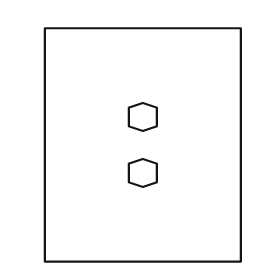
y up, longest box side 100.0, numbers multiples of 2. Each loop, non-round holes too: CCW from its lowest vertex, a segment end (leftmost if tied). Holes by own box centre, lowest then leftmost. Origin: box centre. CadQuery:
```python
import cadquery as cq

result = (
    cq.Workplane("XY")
    .moveTo(-42.0, -50.0)
    .lineTo(42.0, -50.0)
    .lineTo(42.0, 50.0)
    .lineTo(-42.0, 50.0)
    .close()
    .moveTo(0.0, -18.0)
    .lineTo(6.0, -16.0)
    .lineTo(6.0, -8.0)
    .lineTo(0.0, -6.0)
    .lineTo(-6.0, -8.0)
    .lineTo(-6.0, -16.0)
    .close()
    .moveTo(0.0, 6.0)
    .lineTo(6.0, 8.0)
    .lineTo(6.0, 16.0)
    .lineTo(0.0, 18.0)
    .lineTo(-6.0, 16.0)
    .lineTo(-6.0, 8.0)
    .close()
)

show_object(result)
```